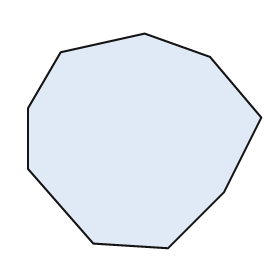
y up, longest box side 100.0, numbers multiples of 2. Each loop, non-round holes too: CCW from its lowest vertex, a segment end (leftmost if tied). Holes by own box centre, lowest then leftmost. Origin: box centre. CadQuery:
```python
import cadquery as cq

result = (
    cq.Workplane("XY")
    .moveTo(10.0, -46.0)
    .lineTo(34.0, -22.0)
    .lineTo(50.0, 10.0)
    .lineTo(28.0, 36.0)
    .lineTo(0.0, 46.0)
    .lineTo(-36.0, 38.0)
    .lineTo(-50.0, 14.0)
    .lineTo(-50.0, -12.0)
    .lineTo(-22.0, -44.0)
    .close()
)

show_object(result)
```